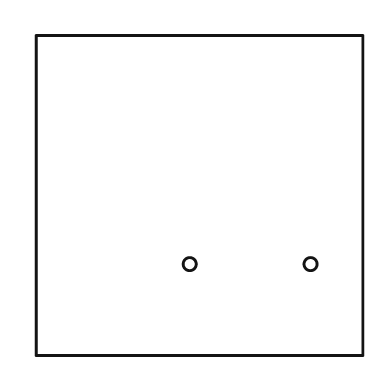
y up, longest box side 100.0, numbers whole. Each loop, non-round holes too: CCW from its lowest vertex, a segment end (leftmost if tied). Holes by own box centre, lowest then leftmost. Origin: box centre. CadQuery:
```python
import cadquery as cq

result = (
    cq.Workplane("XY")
    .moveTo(-50.0, -49.0)
    .lineTo(50.0, -49.0)
    .lineTo(50.0, 49.0)
    .lineTo(-50.0, 49.0)
    .close()
    .moveTo(-3.0, -21.0)
    .circle(2.0)
    .moveTo(34.0, -21.0)
    .circle(2.0)
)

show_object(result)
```